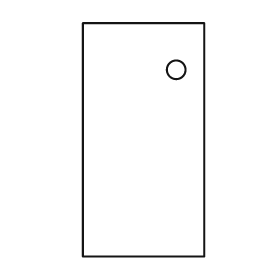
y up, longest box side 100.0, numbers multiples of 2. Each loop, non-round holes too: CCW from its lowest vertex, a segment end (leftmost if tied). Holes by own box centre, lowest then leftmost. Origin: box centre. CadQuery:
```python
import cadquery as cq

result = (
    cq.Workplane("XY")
    .moveTo(-26.0, -50.0)
    .lineTo(26.0, -50.0)
    .lineTo(26.0, 50.0)
    .lineTo(-26.0, 50.0)
    .close()
    .moveTo(14.0, 30.0)
    .circle(4.0)
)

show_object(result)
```